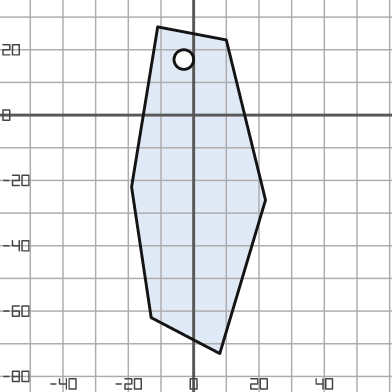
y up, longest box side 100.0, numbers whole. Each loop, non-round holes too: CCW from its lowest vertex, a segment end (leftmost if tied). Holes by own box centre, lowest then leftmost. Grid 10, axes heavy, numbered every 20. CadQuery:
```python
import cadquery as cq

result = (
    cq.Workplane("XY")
    .moveTo(8.0, -73.0)
    .lineTo(22.0, -26.0)
    .lineTo(10.0, 23.0)
    .lineTo(-11.0, 27.0)
    .lineTo(-19.0, -22.0)
    .lineTo(-13.0, -62.0)
    .close()
    .moveTo(-3.0, 17.0)
    .circle(3.0)
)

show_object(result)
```